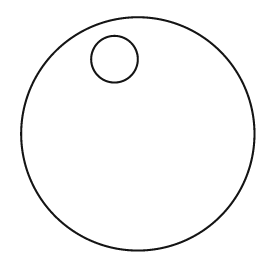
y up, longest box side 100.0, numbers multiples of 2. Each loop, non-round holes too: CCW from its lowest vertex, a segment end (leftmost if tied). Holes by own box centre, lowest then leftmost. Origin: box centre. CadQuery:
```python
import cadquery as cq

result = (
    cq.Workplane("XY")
    .moveTo(0.0, 0.0)
    .circle(50.0)
    .moveTo(-10.0, 32.0)
    .circle(10.0)
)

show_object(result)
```